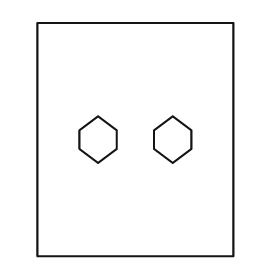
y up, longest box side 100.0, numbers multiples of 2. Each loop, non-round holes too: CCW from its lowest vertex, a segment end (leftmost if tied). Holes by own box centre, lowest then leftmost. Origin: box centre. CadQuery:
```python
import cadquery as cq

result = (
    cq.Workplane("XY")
    .moveTo(-42.0, -50.0)
    .lineTo(42.0, -50.0)
    .lineTo(42.0, 50.0)
    .lineTo(-42.0, 50.0)
    .close()
    .moveTo(-16.0, -10.0)
    .lineTo(-8.0, -4.0)
    .lineTo(-8.0, 4.0)
    .lineTo(-16.0, 10.0)
    .lineTo(-24.0, 4.0)
    .lineTo(-24.0, -4.0)
    .close()
    .moveTo(16.0, -10.0)
    .lineTo(24.0, -4.0)
    .lineTo(24.0, 4.0)
    .lineTo(16.0, 10.0)
    .lineTo(8.0, 4.0)
    .lineTo(8.0, -4.0)
    .close()
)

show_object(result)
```